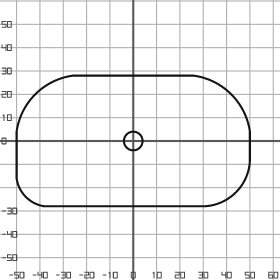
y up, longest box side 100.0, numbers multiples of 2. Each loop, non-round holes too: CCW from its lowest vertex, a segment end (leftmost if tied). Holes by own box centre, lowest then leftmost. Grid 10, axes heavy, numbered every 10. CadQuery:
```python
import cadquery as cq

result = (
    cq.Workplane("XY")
    .moveTo(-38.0, -28.0)
    .lineTo(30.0, -28.0)
    .threePointArc((44.0, -22.0), (50.0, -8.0))
    .lineTo(50.0, 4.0)
    .threePointArc((42.0, 20.0), (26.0, 28.0))
    .lineTo(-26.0, 28.0)
    .threePointArc((-42.0, 20.0), (-50.0, 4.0))
    .lineTo(-50.0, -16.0)
    .threePointArc((-46.0, -24.0), (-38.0, -28.0))
    .close()
    .moveTo(0.0, 0.0)
    .circle(4.0)
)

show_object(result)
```